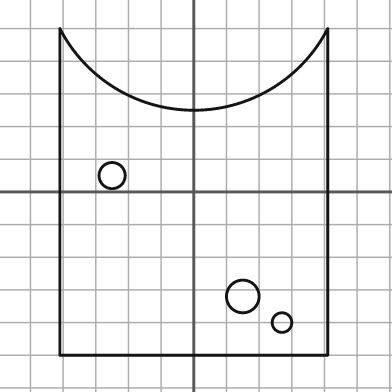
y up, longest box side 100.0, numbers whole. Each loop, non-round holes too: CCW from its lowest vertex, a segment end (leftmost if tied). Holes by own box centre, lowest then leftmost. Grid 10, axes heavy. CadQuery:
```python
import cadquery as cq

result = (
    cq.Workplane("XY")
    .moveTo(-41.0, -50.0)
    .lineTo(41.0, -50.0)
    .lineTo(41.0, 50.0)
    .threePointArc((0.0, 25.0), (-41.0, 50.0))
    .close()
    .moveTo(27.0, -40.0)
    .circle(3.0)
    .moveTo(15.0, -32.0)
    .circle(5.0)
    .moveTo(-25.0, 5.0)
    .circle(4.0)
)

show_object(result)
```